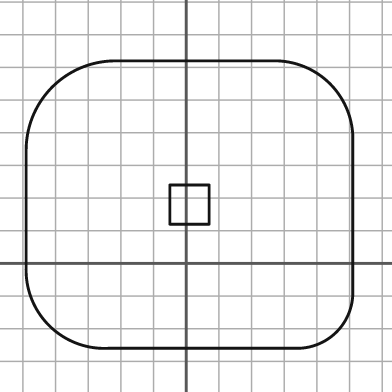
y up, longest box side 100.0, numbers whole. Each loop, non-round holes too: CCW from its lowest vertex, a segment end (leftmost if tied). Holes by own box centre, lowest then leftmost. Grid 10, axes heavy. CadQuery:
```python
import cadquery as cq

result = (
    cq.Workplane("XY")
    .moveTo(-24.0, -26.0)
    .lineTo(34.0, -26.0)
    .threePointArc((46.0, -21.0), (51.0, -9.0))
    .lineTo(51.0, 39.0)
    .threePointArc((44.0, 55.0), (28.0, 62.0))
    .lineTo(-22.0, 62.0)
    .threePointArc((-41.0, 54.0), (-49.0, 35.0))
    .lineTo(-49.0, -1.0)
    .threePointArc((-42.0, -19.0), (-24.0, -26.0))
    .close()
    .moveTo(-5.0, 12.0)
    .lineTo(7.0, 12.0)
    .lineTo(7.0, 24.0)
    .lineTo(-5.0, 24.0)
    .close()
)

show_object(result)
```